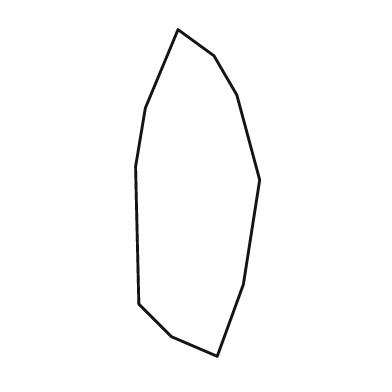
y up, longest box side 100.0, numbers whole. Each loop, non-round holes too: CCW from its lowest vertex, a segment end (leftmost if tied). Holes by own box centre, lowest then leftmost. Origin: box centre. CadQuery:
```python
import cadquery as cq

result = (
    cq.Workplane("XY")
    .moveTo(6.0, -50.0)
    .lineTo(14.0, -28.0)
    .lineTo(19.0, 4.0)
    .lineTo(12.0, 30.0)
    .lineTo(5.0, 42.0)
    .lineTo(-6.0, 50.0)
    .lineTo(-16.0, 26.0)
    .lineTo(-19.0, 8.0)
    .lineTo(-18.0, -34.0)
    .lineTo(-8.0, -44.0)
    .close()
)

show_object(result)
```